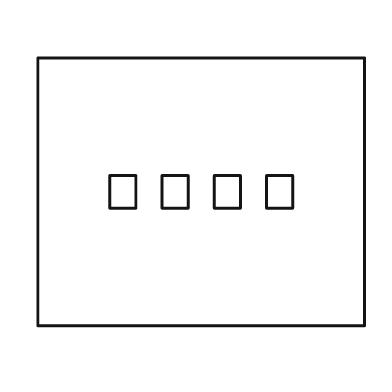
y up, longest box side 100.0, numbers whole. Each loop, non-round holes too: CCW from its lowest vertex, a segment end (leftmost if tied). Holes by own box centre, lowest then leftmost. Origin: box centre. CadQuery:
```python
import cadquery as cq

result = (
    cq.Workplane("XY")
    .moveTo(-50.0, -41.0)
    .lineTo(50.0, -41.0)
    .lineTo(50.0, 41.0)
    .lineTo(-50.0, 41.0)
    .close()
    .moveTo(-28.0, -5.0)
    .lineTo(-20.0, -5.0)
    .lineTo(-20.0, 5.0)
    .lineTo(-28.0, 5.0)
    .close()
    .moveTo(-12.0, -5.0)
    .lineTo(-4.0, -5.0)
    .lineTo(-4.0, 5.0)
    .lineTo(-12.0, 5.0)
    .close()
    .moveTo(4.0, -5.0)
    .lineTo(12.0, -5.0)
    .lineTo(12.0, 5.0)
    .lineTo(4.0, 5.0)
    .close()
    .moveTo(20.0, -5.0)
    .lineTo(28.0, -5.0)
    .lineTo(28.0, 5.0)
    .lineTo(20.0, 5.0)
    .close()
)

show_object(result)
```